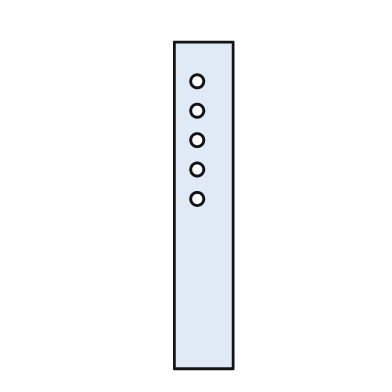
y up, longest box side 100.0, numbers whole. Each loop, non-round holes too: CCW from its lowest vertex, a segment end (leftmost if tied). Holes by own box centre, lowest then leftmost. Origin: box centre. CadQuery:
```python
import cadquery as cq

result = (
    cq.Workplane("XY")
    .moveTo(-9.0, -50.0)
    .lineTo(9.0, -50.0)
    .lineTo(9.0, 50.0)
    .lineTo(-9.0, 50.0)
    .close()
    .moveTo(-2.0, 2.0)
    .circle(2.0)
    .moveTo(-2.0, 11.0)
    .circle(2.0)
    .moveTo(-2.0, 20.0)
    .circle(2.0)
    .moveTo(-2.0, 29.0)
    .circle(2.0)
    .moveTo(-2.0, 38.0)
    .circle(2.0)
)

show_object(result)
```